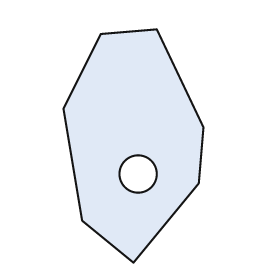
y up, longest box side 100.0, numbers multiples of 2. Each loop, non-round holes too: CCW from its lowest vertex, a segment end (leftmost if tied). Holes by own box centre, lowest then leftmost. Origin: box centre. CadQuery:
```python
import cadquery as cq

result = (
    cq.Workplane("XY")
    .moveTo(0.0, -50.0)
    .lineTo(28.0, -16.0)
    .lineTo(30.0, 8.0)
    .lineTo(10.0, 50.0)
    .lineTo(-14.0, 48.0)
    .lineTo(-30.0, 16.0)
    .lineTo(-22.0, -32.0)
    .close()
    .moveTo(2.0, -12.0)
    .circle(8.0)
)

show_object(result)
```